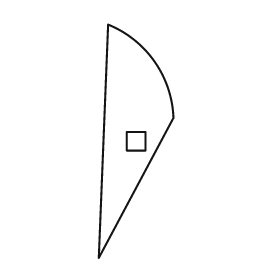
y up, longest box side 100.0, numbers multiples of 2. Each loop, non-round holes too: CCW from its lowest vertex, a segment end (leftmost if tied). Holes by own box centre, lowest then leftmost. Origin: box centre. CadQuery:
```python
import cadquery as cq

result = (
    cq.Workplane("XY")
    .moveTo(-16.0, -50.0)
    .lineTo(16.0, 10.0)
    .threePointArc((8.0, 34.0), (-12.0, 50.0))
    .close()
    .moveTo(-4.0, -4.0)
    .lineTo(4.0, -4.0)
    .lineTo(4.0, 4.0)
    .lineTo(-4.0, 4.0)
    .close()
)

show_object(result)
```